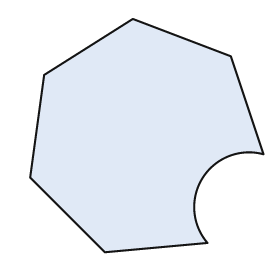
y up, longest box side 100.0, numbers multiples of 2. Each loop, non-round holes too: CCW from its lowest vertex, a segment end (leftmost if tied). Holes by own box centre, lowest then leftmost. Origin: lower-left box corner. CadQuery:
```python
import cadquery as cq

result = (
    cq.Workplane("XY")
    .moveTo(32.0, 0.0)
    .lineTo(76.0, 4.0)
    .threePointArc((74.0, 32.0), (100.0, 42.0))
    .lineTo(86.0, 84.0)
    .lineTo(44.0, 100.0)
    .lineTo(6.0, 76.0)
    .lineTo(0.0, 32.0)
    .close()
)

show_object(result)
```